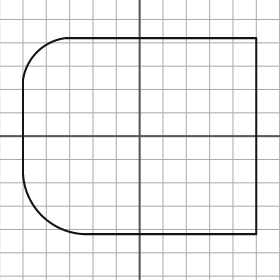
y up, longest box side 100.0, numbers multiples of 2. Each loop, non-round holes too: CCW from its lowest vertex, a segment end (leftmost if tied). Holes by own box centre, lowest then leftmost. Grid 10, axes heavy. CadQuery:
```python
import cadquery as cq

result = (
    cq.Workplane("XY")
    .moveTo(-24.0, -42.0)
    .lineTo(50.0, -42.0)
    .lineTo(50.0, 42.0)
    .lineTo(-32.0, 42.0)
    .threePointArc((-44.0, 36.0), (-50.0, 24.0))
    .lineTo(-50.0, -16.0)
    .threePointArc((-42.0, -34.0), (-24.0, -42.0))
    .close()
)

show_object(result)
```